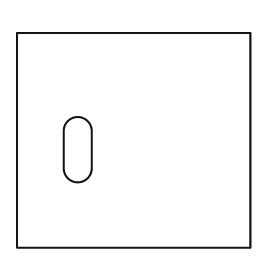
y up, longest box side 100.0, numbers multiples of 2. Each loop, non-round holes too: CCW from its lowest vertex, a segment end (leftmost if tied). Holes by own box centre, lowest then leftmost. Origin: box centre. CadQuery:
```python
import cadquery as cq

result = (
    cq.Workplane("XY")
    .moveTo(-50.0, -46.0)
    .lineTo(50.0, -46.0)
    .lineTo(50.0, 46.0)
    .lineTo(-50.0, 46.0)
    .close()
    .moveTo(-30.0, -12.0)
    .threePointArc((-24.0, -18.0), (-18.0, -12.0))
    .lineTo(-18.0, 4.0)
    .threePointArc((-24.0, 10.0), (-30.0, 4.0))
    .close()
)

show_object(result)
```